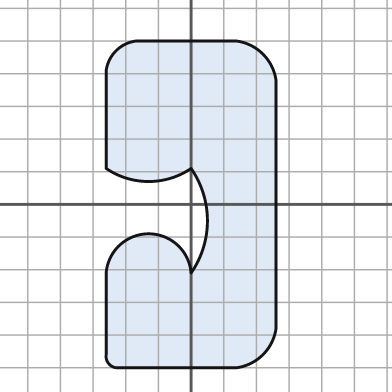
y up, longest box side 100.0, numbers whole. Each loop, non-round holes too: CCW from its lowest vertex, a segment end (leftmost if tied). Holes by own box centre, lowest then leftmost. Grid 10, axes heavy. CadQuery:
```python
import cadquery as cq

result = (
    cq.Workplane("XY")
    .moveTo(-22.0, -50.0)
    .lineTo(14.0, -50.0)
    .threePointArc((22.0, -46.0), (26.0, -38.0))
    .lineTo(26.0, 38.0)
    .threePointArc((22.0, 46.0), (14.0, 50.0))
    .lineTo(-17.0, 50.0)
    .threePointArc((-23.0, 47.0), (-26.0, 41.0))
    .lineTo(-26.0, 11.0)
    .threePointArc((-13.0, 7.0), (0.0, 11.0))
    .threePointArc((5.0, -5.0), (0.0, -21.0))
    .threePointArc((-13.0, -9.0), (-26.0, -21.0))
    .lineTo(-26.0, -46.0)
    .threePointArc((-25.0, -49.0), (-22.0, -50.0))
    .close()
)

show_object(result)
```